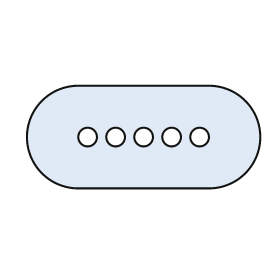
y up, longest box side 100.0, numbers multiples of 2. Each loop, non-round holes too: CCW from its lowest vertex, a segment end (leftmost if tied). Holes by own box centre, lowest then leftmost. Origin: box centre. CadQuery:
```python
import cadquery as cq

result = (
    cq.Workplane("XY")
    .moveTo(-28.0, -22.0)
    .lineTo(28.0, -22.0)
    .threePointArc((50.0, 0.0), (28.0, 22.0))
    .lineTo(-28.0, 22.0)
    .threePointArc((-50.0, 0.0), (-28.0, -22.0))
    .close()
    .moveTo(-24.0, 0.0)
    .circle(4.0)
    .moveTo(-12.0, 0.0)
    .circle(4.0)
    .moveTo(0.0, 0.0)
    .circle(4.0)
    .moveTo(12.0, 0.0)
    .circle(4.0)
    .moveTo(24.0, 0.0)
    .circle(4.0)
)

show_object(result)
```